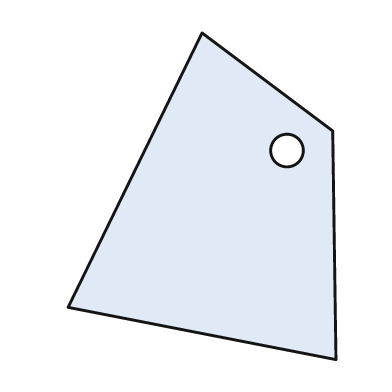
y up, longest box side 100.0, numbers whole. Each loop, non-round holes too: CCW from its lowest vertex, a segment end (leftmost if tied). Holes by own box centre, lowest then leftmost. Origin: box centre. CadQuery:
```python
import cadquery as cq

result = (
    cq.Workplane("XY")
    .moveTo(41.0, -50.0)
    .lineTo(40.0, 20.0)
    .lineTo(0.0, 50.0)
    .lineTo(-41.0, -34.0)
    .close()
    .moveTo(26.0, 14.0)
    .circle(5.0)
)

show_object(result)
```